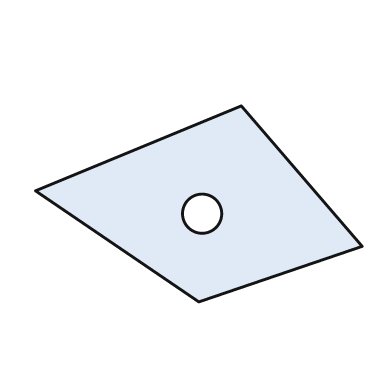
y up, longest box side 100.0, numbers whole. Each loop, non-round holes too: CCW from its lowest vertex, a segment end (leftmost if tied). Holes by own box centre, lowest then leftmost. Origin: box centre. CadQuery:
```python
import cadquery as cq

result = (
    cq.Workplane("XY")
    .moveTo(0.0, -30.0)
    .lineTo(50.0, -13.0)
    .lineTo(13.0, 30.0)
    .lineTo(-50.0, 4.0)
    .close()
    .moveTo(1.0, -3.0)
    .circle(6.0)
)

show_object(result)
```